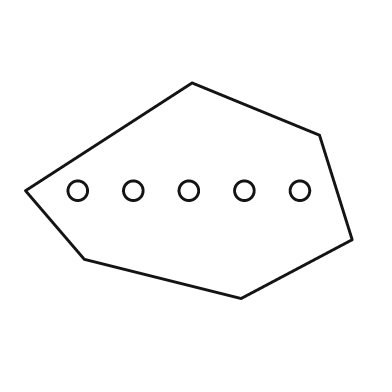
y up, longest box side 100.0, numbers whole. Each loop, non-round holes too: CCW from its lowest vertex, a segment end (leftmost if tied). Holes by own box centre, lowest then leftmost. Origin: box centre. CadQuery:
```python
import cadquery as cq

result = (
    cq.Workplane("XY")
    .moveTo(16.0, -33.0)
    .lineTo(50.0, -15.0)
    .lineTo(40.0, 17.0)
    .lineTo(1.0, 33.0)
    .lineTo(-50.0, 0.0)
    .lineTo(-32.0, -21.0)
    .close()
    .moveTo(-34.0, 0.0)
    .circle(3.0)
    .moveTo(-17.0, 0.0)
    .circle(3.0)
    .moveTo(0.0, 0.0)
    .circle(3.0)
    .moveTo(17.0, 0.0)
    .circle(3.0)
    .moveTo(34.0, 0.0)
    .circle(3.0)
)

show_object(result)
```